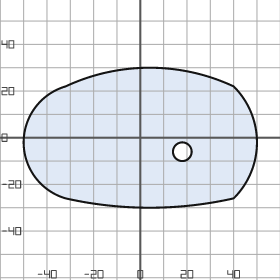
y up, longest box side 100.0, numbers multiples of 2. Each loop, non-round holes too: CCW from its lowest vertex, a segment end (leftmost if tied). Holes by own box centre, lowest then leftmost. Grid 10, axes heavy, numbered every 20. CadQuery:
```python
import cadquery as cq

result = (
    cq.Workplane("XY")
    .moveTo(-32.0, -26.0)
    .threePointArc((4.0, -30.0), (40.0, -26.0))
    .threePointArc((50.0, -2.0), (40.0, 22.0))
    .threePointArc((4.0, 30.0), (-32.0, 22.0))
    .threePointArc((-50.0, -2.0), (-32.0, -26.0))
    .close()
    .moveTo(18.0, -6.0)
    .circle(4.0)
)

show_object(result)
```